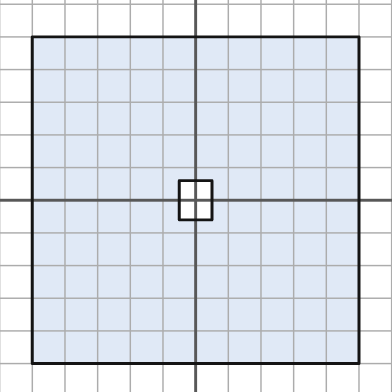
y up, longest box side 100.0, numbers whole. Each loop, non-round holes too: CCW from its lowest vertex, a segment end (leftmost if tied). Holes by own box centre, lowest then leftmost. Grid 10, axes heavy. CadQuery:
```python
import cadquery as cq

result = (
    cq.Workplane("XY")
    .moveTo(-50.0, -50.0)
    .lineTo(50.0, -50.0)
    .lineTo(50.0, 50.0)
    .lineTo(-50.0, 50.0)
    .close()
    .moveTo(-5.0, -6.0)
    .lineTo(5.0, -6.0)
    .lineTo(5.0, 6.0)
    .lineTo(-5.0, 6.0)
    .close()
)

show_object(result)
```